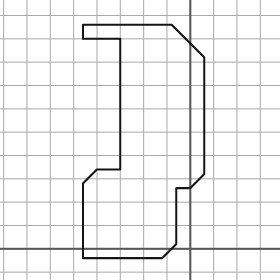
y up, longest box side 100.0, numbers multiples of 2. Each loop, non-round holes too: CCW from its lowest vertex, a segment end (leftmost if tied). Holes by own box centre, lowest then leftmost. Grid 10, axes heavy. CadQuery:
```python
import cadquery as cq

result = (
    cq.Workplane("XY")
    .moveTo(-46.0, -4.0)
    .lineTo(-12.0, -4.0)
    .lineTo(-6.0, 2.0)
    .lineTo(-6.0, 26.0)
    .lineTo(0.0, 26.0)
    .lineTo(6.0, 32.0)
    .lineTo(6.0, 82.0)
    .lineTo(-8.0, 96.0)
    .lineTo(-46.0, 96.0)
    .lineTo(-46.0, 90.0)
    .lineTo(-30.0, 90.0)
    .lineTo(-30.0, 34.0)
    .lineTo(-40.0, 34.0)
    .lineTo(-46.0, 28.0)
    .close()
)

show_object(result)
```